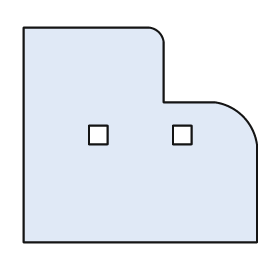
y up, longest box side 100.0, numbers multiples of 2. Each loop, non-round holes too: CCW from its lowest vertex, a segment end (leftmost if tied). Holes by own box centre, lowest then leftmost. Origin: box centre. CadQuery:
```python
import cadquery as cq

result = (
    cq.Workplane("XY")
    .moveTo(-50.0, -46.0)
    .lineTo(50.0, -46.0)
    .lineTo(50.0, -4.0)
    .threePointArc((44.0, 8.0), (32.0, 14.0))
    .lineTo(10.0, 14.0)
    .lineTo(10.0, 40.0)
    .threePointArc((8.0, 44.0), (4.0, 46.0))
    .lineTo(-50.0, 46.0)
    .close()
    .moveTo(-22.0, -4.0)
    .lineTo(-14.0, -4.0)
    .lineTo(-14.0, 4.0)
    .lineTo(-22.0, 4.0)
    .close()
    .moveTo(14.0, -4.0)
    .lineTo(22.0, -4.0)
    .lineTo(22.0, 4.0)
    .lineTo(14.0, 4.0)
    .close()
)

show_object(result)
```